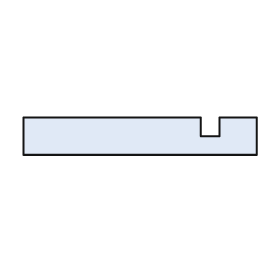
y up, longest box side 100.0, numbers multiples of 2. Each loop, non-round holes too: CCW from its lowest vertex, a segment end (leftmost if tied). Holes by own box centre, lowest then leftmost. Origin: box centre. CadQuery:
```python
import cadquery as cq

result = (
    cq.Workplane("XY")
    .moveTo(-50.0, -8.0)
    .lineTo(50.0, -8.0)
    .lineTo(50.0, 8.0)
    .lineTo(34.0, 8.0)
    .lineTo(34.0, 0.0)
    .lineTo(26.0, 0.0)
    .lineTo(26.0, 8.0)
    .lineTo(-50.0, 8.0)
    .close()
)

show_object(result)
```